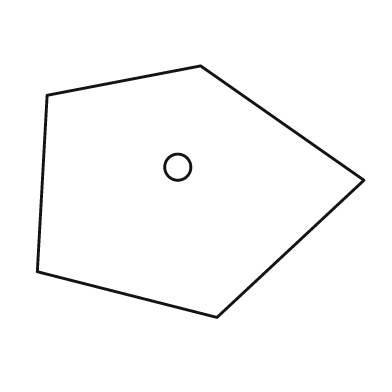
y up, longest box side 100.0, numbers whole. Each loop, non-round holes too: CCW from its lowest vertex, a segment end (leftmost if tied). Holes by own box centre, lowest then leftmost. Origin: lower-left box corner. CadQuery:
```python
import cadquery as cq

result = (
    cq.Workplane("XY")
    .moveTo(55.0, 0.0)
    .lineTo(100.0, 42.0)
    .lineTo(50.0, 77.0)
    .lineTo(3.0, 68.0)
    .lineTo(0.0, 14.0)
    .close()
    .moveTo(43.0, 46.0)
    .circle(4.0)
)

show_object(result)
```